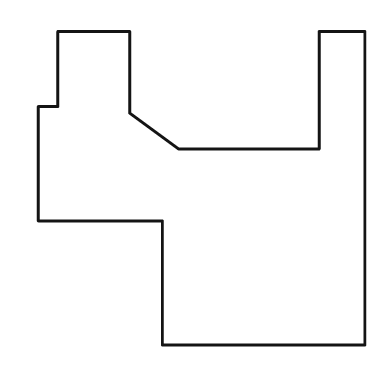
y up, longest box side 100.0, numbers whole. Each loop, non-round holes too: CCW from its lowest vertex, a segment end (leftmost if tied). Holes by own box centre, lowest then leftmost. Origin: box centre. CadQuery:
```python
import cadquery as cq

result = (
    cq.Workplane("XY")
    .moveTo(-12.0, -48.0)
    .lineTo(50.0, -48.0)
    .lineTo(50.0, 48.0)
    .lineTo(36.0, 48.0)
    .lineTo(36.0, 12.0)
    .lineTo(-7.0, 12.0)
    .lineTo(-22.0, 23.0)
    .lineTo(-22.0, 48.0)
    .lineTo(-44.0, 48.0)
    .lineTo(-44.0, 25.0)
    .lineTo(-50.0, 25.0)
    .lineTo(-50.0, -10.0)
    .lineTo(-12.0, -10.0)
    .close()
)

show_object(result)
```